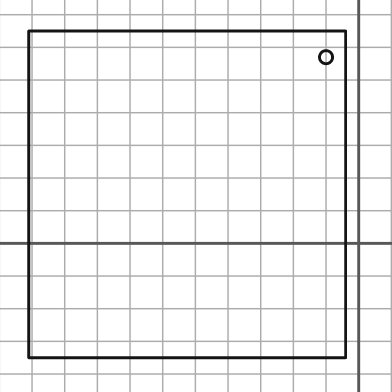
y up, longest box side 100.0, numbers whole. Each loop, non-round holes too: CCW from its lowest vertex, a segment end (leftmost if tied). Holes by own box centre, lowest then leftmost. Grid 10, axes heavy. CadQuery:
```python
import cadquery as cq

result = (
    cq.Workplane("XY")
    .moveTo(-101.0, -35.0)
    .lineTo(-4.0, -35.0)
    .lineTo(-4.0, 65.0)
    .lineTo(-101.0, 65.0)
    .close()
    .moveTo(-10.0, 57.0)
    .circle(2.0)
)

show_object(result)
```